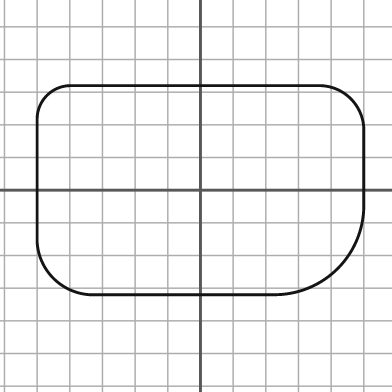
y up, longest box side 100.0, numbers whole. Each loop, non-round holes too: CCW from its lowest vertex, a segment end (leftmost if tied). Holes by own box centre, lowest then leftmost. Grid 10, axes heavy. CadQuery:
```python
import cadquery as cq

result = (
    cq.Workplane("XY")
    .moveTo(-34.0, -32.0)
    .lineTo(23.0, -32.0)
    .threePointArc((42.0, -24.0), (50.0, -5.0))
    .lineTo(50.0, 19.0)
    .threePointArc((46.0, 28.0), (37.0, 32.0))
    .lineTo(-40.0, 32.0)
    .threePointArc((-47.0, 29.0), (-50.0, 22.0))
    .lineTo(-50.0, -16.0)
    .threePointArc((-45.0, -27.0), (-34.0, -32.0))
    .close()
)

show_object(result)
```